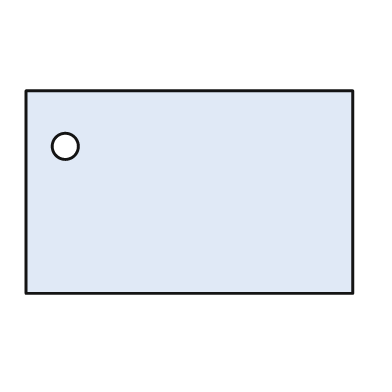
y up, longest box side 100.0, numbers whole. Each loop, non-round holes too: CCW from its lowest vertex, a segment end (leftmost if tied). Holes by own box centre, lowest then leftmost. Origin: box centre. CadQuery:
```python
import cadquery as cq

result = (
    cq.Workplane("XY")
    .moveTo(-50.0, -31.0)
    .lineTo(50.0, -31.0)
    .lineTo(50.0, 31.0)
    .lineTo(-50.0, 31.0)
    .close()
    .moveTo(-38.0, 14.0)
    .circle(4.0)
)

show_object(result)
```